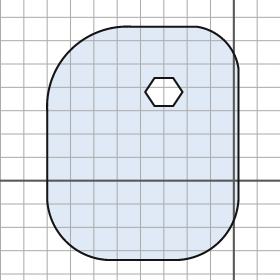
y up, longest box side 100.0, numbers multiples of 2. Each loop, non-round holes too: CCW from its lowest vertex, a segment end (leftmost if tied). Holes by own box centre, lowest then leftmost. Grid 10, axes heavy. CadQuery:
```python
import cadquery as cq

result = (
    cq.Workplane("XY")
    .moveTo(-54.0, -34.0)
    .lineTo(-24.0, -34.0)
    .threePointArc((-6.0, -26.0), (2.0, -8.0))
    .lineTo(2.0, 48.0)
    .threePointArc((-4.0, 60.0), (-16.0, 66.0))
    .lineTo(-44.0, 66.0)
    .threePointArc((-70.0, 56.0), (-80.0, 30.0))
    .lineTo(-80.0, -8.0)
    .threePointArc((-72.0, -26.0), (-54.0, -34.0))
    .close()
    .moveTo(-34.0, 32.0)
    .lineTo(-26.0, 32.0)
    .lineTo(-22.0, 38.0)
    .lineTo(-26.0, 44.0)
    .lineTo(-34.0, 44.0)
    .lineTo(-38.0, 38.0)
    .close()
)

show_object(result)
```